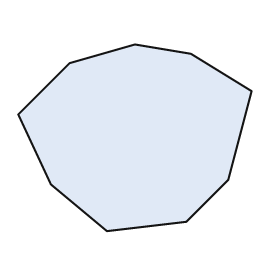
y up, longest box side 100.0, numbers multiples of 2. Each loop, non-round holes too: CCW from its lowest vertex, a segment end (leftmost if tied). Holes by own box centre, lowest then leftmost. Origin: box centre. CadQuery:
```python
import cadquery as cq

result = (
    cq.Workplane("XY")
    .moveTo(-12.0, -40.0)
    .lineTo(22.0, -36.0)
    .lineTo(40.0, -18.0)
    .lineTo(50.0, 20.0)
    .lineTo(24.0, 36.0)
    .lineTo(0.0, 40.0)
    .lineTo(-28.0, 32.0)
    .lineTo(-50.0, 10.0)
    .lineTo(-36.0, -20.0)
    .close()
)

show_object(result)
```